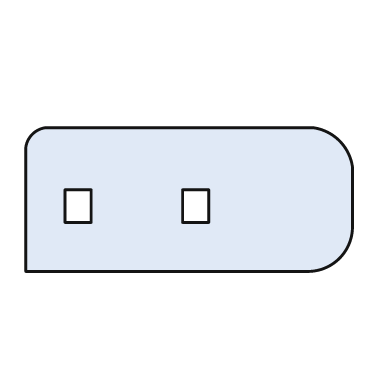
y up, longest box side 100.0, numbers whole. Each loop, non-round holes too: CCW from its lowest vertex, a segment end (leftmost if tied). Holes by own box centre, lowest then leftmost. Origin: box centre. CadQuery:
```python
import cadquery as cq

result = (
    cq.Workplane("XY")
    .moveTo(-50.0, -22.0)
    .lineTo(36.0, -22.0)
    .threePointArc((46.0, -18.0), (50.0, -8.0))
    .lineTo(50.0, 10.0)
    .threePointArc((46.0, 18.0), (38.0, 22.0))
    .lineTo(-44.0, 22.0)
    .threePointArc((-48.0, 20.0), (-50.0, 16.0))
    .close()
    .moveTo(-38.0, -7.0)
    .lineTo(-30.0, -7.0)
    .lineTo(-30.0, 3.0)
    .lineTo(-38.0, 3.0)
    .close()
    .moveTo(-2.0, -7.0)
    .lineTo(6.0, -7.0)
    .lineTo(6.0, 3.0)
    .lineTo(-2.0, 3.0)
    .close()
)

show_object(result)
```